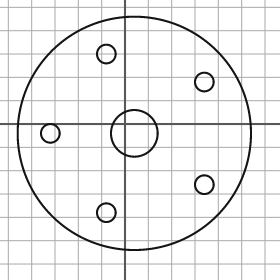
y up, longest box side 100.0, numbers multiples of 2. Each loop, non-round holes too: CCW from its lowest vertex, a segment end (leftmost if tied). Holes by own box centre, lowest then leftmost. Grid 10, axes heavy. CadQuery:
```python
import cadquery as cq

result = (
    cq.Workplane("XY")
    .moveTo(4.0, -4.0)
    .circle(50.0)
    .moveTo(-8.0, -38.0)
    .circle(4.0)
    .moveTo(34.0, -26.0)
    .circle(4.0)
    .moveTo(-32.0, -4.0)
    .circle(4.0)
    .moveTo(4.0, -4.0)
    .circle(10.0)
    .moveTo(34.0, 18.0)
    .circle(4.0)
    .moveTo(-8.0, 30.0)
    .circle(4.0)
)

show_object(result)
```